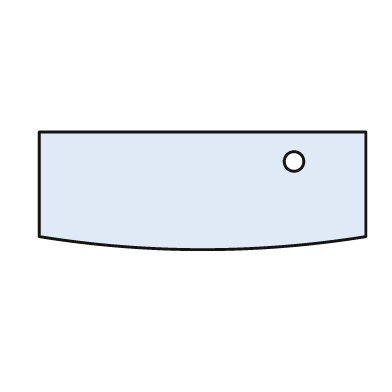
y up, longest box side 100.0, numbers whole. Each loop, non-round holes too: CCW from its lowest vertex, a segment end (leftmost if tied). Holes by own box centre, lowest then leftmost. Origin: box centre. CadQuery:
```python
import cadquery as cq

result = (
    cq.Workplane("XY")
    .moveTo(-50.0, -14.0)
    .threePointArc((0.0, -18.0), (50.0, -14.0))
    .lineTo(50.0, 18.0)
    .lineTo(-50.0, 18.0)
    .close()
    .moveTo(28.0, 9.0)
    .circle(3.0)
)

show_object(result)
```